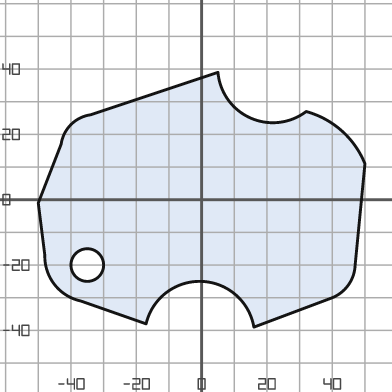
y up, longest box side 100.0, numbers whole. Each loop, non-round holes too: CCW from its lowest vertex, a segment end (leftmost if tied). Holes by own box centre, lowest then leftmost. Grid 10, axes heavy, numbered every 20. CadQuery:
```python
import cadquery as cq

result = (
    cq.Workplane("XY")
    .moveTo(16.0, -39.0)
    .lineTo(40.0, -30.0)
    .threePointArc((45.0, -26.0), (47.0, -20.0))
    .lineTo(50.0, 11.0)
    .threePointArc((43.0, 21.0), (32.0, 27.0))
    .threePointArc((15.0, 25.0), (5.0, 39.0))
    .lineTo(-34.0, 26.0)
    .threePointArc((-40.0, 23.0), (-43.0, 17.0))
    .lineTo(-50.0, -1.0)
    .lineTo(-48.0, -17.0)
    .threePointArc((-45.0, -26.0), (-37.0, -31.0))
    .lineTo(-17.0, -38.0)
    .threePointArc((0.0, -25.0), (16.0, -39.0))
    .close()
    .moveTo(-35.0, -20.0)
    .circle(5.0)
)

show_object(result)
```